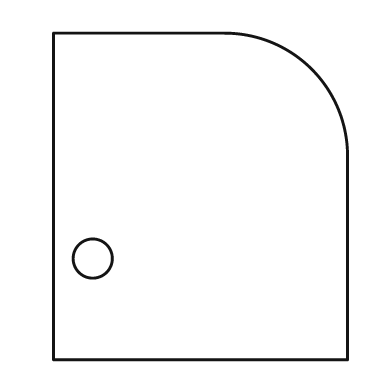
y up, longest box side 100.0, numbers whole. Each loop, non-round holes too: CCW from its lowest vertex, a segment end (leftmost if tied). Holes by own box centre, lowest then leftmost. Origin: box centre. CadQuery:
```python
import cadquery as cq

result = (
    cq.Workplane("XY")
    .moveTo(-45.0, -50.0)
    .lineTo(45.0, -50.0)
    .lineTo(45.0, 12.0)
    .threePointArc((34.0, 39.0), (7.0, 50.0))
    .lineTo(-45.0, 50.0)
    .close()
    .moveTo(-33.0, -19.0)
    .circle(6.0)
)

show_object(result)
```